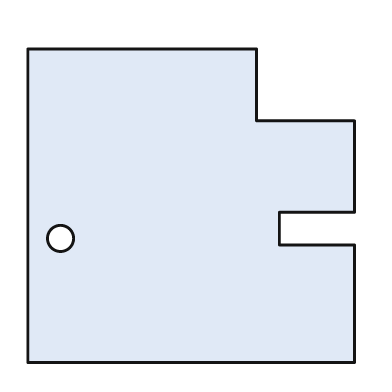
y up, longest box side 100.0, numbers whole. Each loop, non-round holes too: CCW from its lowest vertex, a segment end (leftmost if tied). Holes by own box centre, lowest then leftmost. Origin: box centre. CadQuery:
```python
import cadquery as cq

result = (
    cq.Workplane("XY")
    .moveTo(-50.0, -48.0)
    .lineTo(50.0, -48.0)
    .lineTo(50.0, -12.0)
    .lineTo(27.0, -12.0)
    .lineTo(27.0, -2.0)
    .lineTo(50.0, -2.0)
    .lineTo(50.0, 26.0)
    .lineTo(20.0, 26.0)
    .lineTo(20.0, 48.0)
    .lineTo(-50.0, 48.0)
    .close()
    .moveTo(-40.0, -10.0)
    .circle(4.0)
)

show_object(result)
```